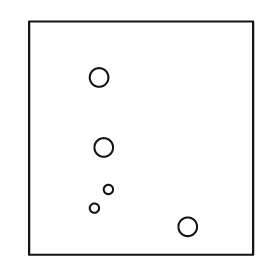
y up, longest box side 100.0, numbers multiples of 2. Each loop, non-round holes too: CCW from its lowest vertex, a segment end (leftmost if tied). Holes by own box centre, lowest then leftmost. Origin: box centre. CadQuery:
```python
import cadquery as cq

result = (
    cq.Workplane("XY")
    .moveTo(-48.0, -50.0)
    .lineTo(48.0, -50.0)
    .lineTo(48.0, 50.0)
    .lineTo(-48.0, 50.0)
    .close()
    .moveTo(20.0, -38.0)
    .circle(4.0)
    .moveTo(-20.0, -30.0)
    .circle(2.0)
    .moveTo(-14.0, -22.0)
    .circle(2.0)
    .moveTo(-16.0, -4.0)
    .circle(4.0)
    .moveTo(-18.0, 26.0)
    .circle(4.0)
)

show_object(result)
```